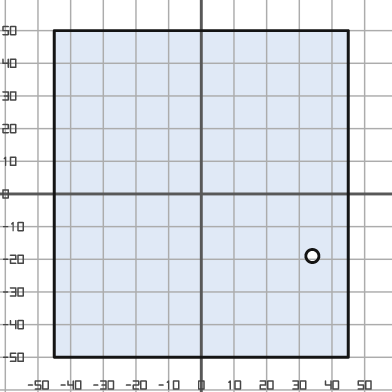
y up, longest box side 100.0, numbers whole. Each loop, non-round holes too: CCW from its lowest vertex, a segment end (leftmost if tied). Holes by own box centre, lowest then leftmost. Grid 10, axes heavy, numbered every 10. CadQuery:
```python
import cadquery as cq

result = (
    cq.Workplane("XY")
    .moveTo(-45.0, -50.0)
    .lineTo(45.0, -50.0)
    .lineTo(45.0, 50.0)
    .lineTo(-45.0, 50.0)
    .close()
    .moveTo(34.0, -19.0)
    .circle(2.0)
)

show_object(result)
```